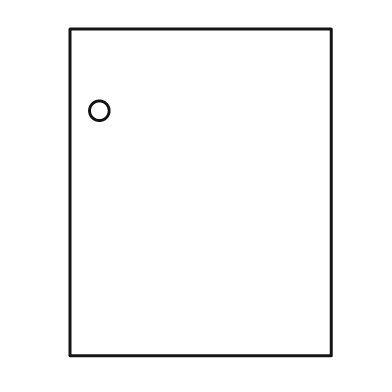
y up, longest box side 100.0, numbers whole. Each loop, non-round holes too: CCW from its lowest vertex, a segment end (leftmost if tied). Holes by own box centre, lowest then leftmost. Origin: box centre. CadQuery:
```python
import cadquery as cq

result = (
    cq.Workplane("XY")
    .moveTo(-40.0, -50.0)
    .lineTo(40.0, -50.0)
    .lineTo(40.0, 50.0)
    .lineTo(-40.0, 50.0)
    .close()
    .moveTo(-31.0, 25.0)
    .circle(3.0)
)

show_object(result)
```